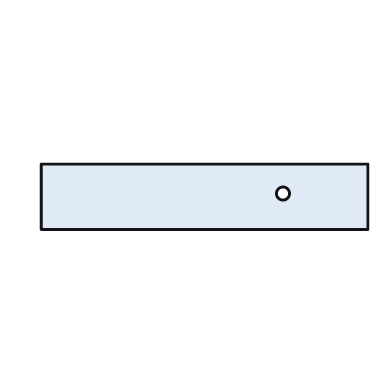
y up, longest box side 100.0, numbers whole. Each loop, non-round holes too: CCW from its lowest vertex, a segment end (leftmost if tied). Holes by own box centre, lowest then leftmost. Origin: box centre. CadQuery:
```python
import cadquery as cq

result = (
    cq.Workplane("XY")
    .moveTo(-50.0, -10.0)
    .lineTo(50.0, -10.0)
    .lineTo(50.0, 10.0)
    .lineTo(-50.0, 10.0)
    .close()
    .moveTo(24.0, 1.0)
    .circle(2.0)
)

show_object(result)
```